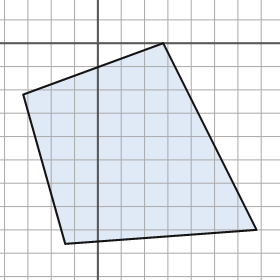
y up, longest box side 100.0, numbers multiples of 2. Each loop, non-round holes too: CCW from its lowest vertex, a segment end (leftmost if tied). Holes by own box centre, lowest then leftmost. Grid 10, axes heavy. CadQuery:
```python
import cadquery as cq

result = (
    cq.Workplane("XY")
    .moveTo(-14.0, -86.0)
    .lineTo(68.0, -80.0)
    .lineTo(28.0, 0.0)
    .lineTo(-32.0, -22.0)
    .close()
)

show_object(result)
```